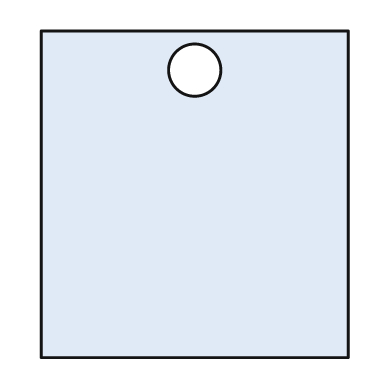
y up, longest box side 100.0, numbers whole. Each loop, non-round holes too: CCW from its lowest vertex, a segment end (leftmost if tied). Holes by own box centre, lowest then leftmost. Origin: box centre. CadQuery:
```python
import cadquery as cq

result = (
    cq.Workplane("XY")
    .moveTo(-47.0, -50.0)
    .lineTo(47.0, -50.0)
    .lineTo(47.0, 50.0)
    .lineTo(-47.0, 50.0)
    .close()
    .moveTo(0.0, 38.0)
    .circle(8.0)
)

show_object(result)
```